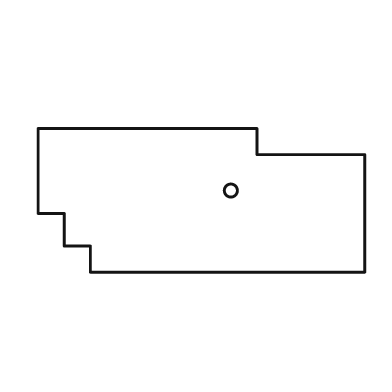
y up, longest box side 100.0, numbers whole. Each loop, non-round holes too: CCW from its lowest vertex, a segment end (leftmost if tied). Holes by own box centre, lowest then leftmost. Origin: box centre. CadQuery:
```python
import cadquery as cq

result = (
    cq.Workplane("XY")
    .moveTo(-34.0, -22.0)
    .lineTo(50.0, -22.0)
    .lineTo(50.0, 14.0)
    .lineTo(17.0, 14.0)
    .lineTo(17.0, 22.0)
    .lineTo(-50.0, 22.0)
    .lineTo(-50.0, -4.0)
    .lineTo(-42.0, -4.0)
    .lineTo(-42.0, -14.0)
    .lineTo(-34.0, -14.0)
    .close()
    .moveTo(9.0, 3.0)
    .circle(2.0)
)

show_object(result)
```